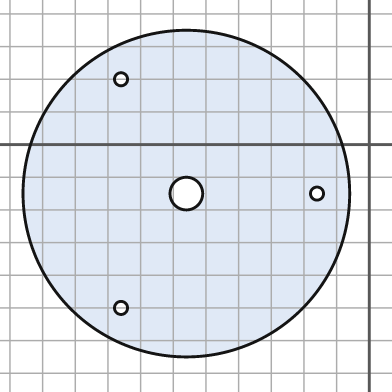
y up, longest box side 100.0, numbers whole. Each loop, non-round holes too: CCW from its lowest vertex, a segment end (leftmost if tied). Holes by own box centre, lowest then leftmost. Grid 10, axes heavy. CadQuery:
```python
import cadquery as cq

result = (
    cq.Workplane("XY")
    .moveTo(-56.0, -15.0)
    .circle(50.0)
    .moveTo(-76.0, -50.0)
    .circle(2.0)
    .moveTo(-56.0, -15.0)
    .circle(5.0)
    .moveTo(-16.0, -15.0)
    .circle(2.0)
    .moveTo(-76.0, 20.0)
    .circle(2.0)
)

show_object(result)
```